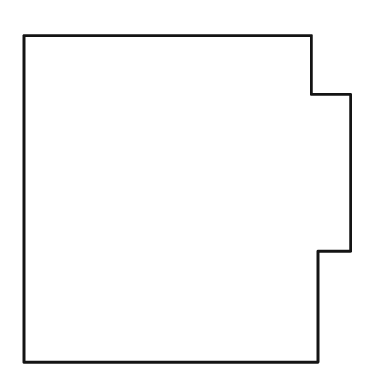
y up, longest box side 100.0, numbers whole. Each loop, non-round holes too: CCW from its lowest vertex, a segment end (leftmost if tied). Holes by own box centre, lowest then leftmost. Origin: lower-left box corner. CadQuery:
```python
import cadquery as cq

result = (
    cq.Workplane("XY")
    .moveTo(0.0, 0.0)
    .lineTo(90.0, 0.0)
    .lineTo(90.0, 34.0)
    .lineTo(100.0, 34.0)
    .lineTo(100.0, 82.0)
    .lineTo(88.0, 82.0)
    .lineTo(88.0, 100.0)
    .lineTo(0.0, 100.0)
    .close()
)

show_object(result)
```